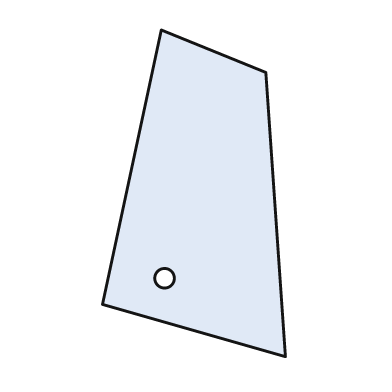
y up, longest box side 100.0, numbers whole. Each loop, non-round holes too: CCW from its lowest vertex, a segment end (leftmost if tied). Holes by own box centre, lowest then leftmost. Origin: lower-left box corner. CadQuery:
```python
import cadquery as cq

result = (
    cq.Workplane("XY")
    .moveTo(56.0, 0.0)
    .lineTo(50.0, 87.0)
    .lineTo(18.0, 100.0)
    .lineTo(0.0, 16.0)
    .close()
    .moveTo(19.0, 24.0)
    .circle(3.0)
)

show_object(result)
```